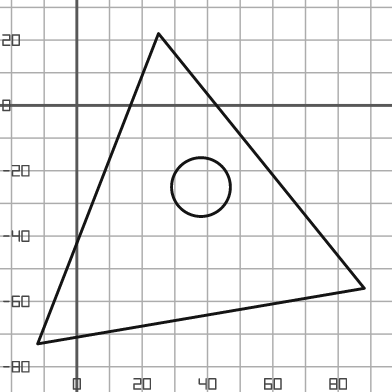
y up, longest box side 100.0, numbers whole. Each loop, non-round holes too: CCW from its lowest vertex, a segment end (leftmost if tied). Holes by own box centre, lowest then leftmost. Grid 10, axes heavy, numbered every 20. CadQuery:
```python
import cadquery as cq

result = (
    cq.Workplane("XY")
    .moveTo(-12.0, -73.0)
    .lineTo(88.0, -56.0)
    .lineTo(25.0, 22.0)
    .close()
    .moveTo(38.0, -25.0)
    .circle(9.0)
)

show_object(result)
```